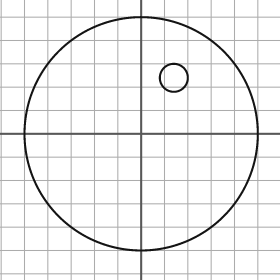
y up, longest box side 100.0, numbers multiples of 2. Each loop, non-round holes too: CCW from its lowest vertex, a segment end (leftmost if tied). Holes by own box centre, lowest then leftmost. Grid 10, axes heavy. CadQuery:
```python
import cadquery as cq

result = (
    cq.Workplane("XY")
    .moveTo(0.0, 0.0)
    .circle(50.0)
    .moveTo(14.0, 24.0)
    .circle(6.0)
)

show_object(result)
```